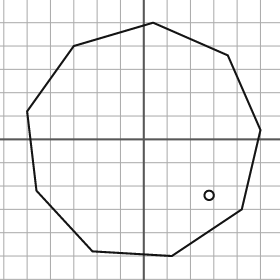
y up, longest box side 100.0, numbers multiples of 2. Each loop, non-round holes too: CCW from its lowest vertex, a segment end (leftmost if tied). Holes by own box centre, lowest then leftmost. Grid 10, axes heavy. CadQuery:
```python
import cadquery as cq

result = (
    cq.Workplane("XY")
    .moveTo(12.0, -50.0)
    .lineTo(42.0, -30.0)
    .lineTo(50.0, 4.0)
    .lineTo(36.0, 36.0)
    .lineTo(4.0, 50.0)
    .lineTo(-30.0, 40.0)
    .lineTo(-50.0, 12.0)
    .lineTo(-46.0, -22.0)
    .lineTo(-22.0, -48.0)
    .close()
    .moveTo(28.0, -24.0)
    .circle(2.0)
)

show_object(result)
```